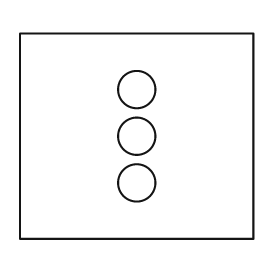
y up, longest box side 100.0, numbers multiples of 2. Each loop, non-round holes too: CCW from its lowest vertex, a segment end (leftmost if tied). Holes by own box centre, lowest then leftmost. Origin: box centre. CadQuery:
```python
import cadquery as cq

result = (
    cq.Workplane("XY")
    .moveTo(-50.0, -44.0)
    .lineTo(50.0, -44.0)
    .lineTo(50.0, 44.0)
    .lineTo(-50.0, 44.0)
    .close()
    .moveTo(0.0, -20.0)
    .circle(8.0)
    .moveTo(0.0, 0.0)
    .circle(8.0)
    .moveTo(0.0, 20.0)
    .circle(8.0)
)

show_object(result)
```